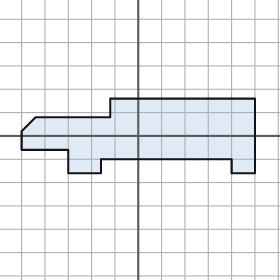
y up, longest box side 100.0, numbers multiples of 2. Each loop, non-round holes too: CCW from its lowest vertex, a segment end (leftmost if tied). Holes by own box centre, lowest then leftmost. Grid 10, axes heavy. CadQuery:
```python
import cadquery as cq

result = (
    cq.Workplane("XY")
    .moveTo(-30.0, -16.0)
    .lineTo(-16.0, -16.0)
    .lineTo(-16.0, -10.0)
    .lineTo(40.0, -10.0)
    .lineTo(40.0, -16.0)
    .lineTo(50.0, -16.0)
    .lineTo(50.0, 16.0)
    .lineTo(-12.0, 16.0)
    .lineTo(-12.0, 8.0)
    .lineTo(-44.0, 8.0)
    .lineTo(-50.0, 2.0)
    .lineTo(-50.0, -6.0)
    .lineTo(-30.0, -6.0)
    .close()
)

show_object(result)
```